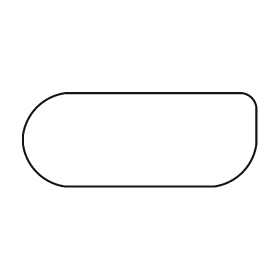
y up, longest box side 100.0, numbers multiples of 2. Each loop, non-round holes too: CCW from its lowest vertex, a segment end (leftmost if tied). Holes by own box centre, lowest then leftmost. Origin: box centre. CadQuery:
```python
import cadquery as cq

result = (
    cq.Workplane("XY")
    .moveTo(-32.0, -20.0)
    .lineTo(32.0, -20.0)
    .threePointArc((44.0, -14.0), (50.0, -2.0))
    .lineTo(50.0, 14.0)
    .threePointArc((48.0, 18.0), (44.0, 20.0))
    .lineTo(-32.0, 20.0)
    .threePointArc((-44.0, 14.0), (-50.0, 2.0))
    .lineTo(-50.0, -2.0)
    .threePointArc((-44.0, -14.0), (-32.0, -20.0))
    .close()
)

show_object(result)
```